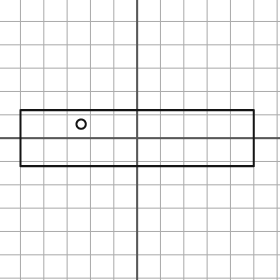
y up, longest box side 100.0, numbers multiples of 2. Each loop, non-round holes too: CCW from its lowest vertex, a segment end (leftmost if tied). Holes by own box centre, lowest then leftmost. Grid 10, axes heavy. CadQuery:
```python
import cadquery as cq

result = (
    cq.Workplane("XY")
    .moveTo(-50.0, -12.0)
    .lineTo(50.0, -12.0)
    .lineTo(50.0, 12.0)
    .lineTo(-50.0, 12.0)
    .close()
    .moveTo(-24.0, 6.0)
    .circle(2.0)
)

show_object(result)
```